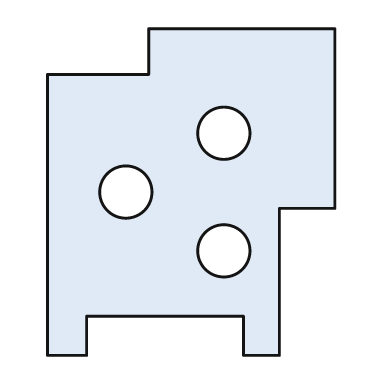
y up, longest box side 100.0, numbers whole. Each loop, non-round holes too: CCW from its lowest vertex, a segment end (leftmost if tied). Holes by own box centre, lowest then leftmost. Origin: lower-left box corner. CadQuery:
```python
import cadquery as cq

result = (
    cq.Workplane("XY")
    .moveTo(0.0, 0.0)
    .lineTo(12.0, 0.0)
    .lineTo(12.0, 12.0)
    .lineTo(60.0, 12.0)
    .lineTo(60.0, 0.0)
    .lineTo(71.0, 0.0)
    .lineTo(71.0, 45.0)
    .lineTo(88.0, 45.0)
    .lineTo(88.0, 100.0)
    .lineTo(31.0, 100.0)
    .lineTo(31.0, 86.0)
    .lineTo(0.0, 86.0)
    .close()
    .moveTo(54.0, 32.0)
    .circle(8.0)
    .moveTo(24.0, 50.0)
    .circle(8.0)
    .moveTo(54.0, 68.0)
    .circle(8.0)
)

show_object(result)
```